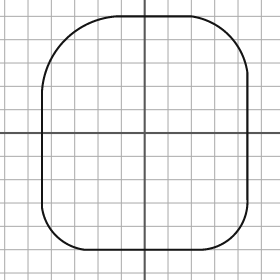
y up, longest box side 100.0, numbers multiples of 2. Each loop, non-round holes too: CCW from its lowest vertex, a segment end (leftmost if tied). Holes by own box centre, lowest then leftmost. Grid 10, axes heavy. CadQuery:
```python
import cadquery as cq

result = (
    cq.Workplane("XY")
    .moveTo(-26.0, -50.0)
    .lineTo(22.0, -50.0)
    .threePointArc((38.0, -44.0), (44.0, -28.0))
    .lineTo(44.0, 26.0)
    .threePointArc((36.0, 42.0), (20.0, 50.0))
    .lineTo(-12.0, 50.0)
    .threePointArc((-34.0, 40.0), (-44.0, 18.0))
    .lineTo(-44.0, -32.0)
    .threePointArc((-38.0, -44.0), (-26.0, -50.0))
    .close()
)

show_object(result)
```